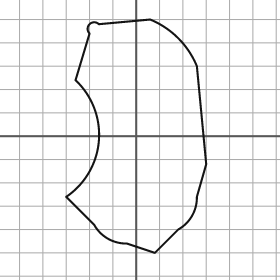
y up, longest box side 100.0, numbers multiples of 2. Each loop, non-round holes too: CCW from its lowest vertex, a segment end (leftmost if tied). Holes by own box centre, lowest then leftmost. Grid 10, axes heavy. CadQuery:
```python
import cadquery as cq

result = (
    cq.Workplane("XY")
    .moveTo(8.0, -50.0)
    .lineTo(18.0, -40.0)
    .threePointArc((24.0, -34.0), (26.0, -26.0))
    .lineTo(30.0, -12.0)
    .lineTo(26.0, 30.0)
    .threePointArc((18.0, 42.0), (6.0, 50.0))
    .lineTo(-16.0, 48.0)
    .threePointArc((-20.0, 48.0), (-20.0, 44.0))
    .lineTo(-26.0, 24.0)
    .threePointArc((-16.0, -2.0), (-30.0, -26.0))
    .lineTo(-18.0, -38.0)
    .threePointArc((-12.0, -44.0), (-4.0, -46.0))
    .close()
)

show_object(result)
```